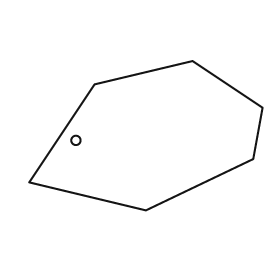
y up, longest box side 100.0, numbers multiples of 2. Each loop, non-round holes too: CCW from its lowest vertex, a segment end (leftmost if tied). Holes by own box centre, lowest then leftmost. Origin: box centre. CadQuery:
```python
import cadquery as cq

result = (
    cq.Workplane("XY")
    .moveTo(0.0, -32.0)
    .lineTo(46.0, -10.0)
    .lineTo(50.0, 12.0)
    .lineTo(20.0, 32.0)
    .lineTo(-22.0, 22.0)
    .lineTo(-50.0, -20.0)
    .close()
    .moveTo(-30.0, -2.0)
    .circle(2.0)
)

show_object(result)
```